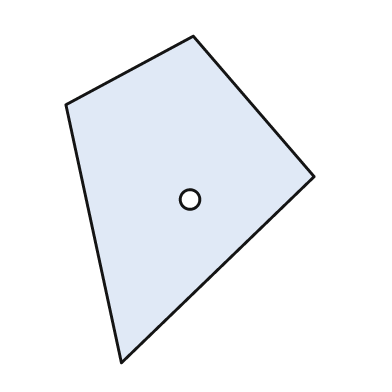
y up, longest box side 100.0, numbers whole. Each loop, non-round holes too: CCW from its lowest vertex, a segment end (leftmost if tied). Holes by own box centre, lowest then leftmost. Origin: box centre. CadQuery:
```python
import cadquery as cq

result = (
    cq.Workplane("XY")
    .moveTo(-21.0, -50.0)
    .lineTo(38.0, 7.0)
    .lineTo(1.0, 50.0)
    .lineTo(-38.0, 29.0)
    .close()
    .moveTo(0.0, 0.0)
    .circle(3.0)
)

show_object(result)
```